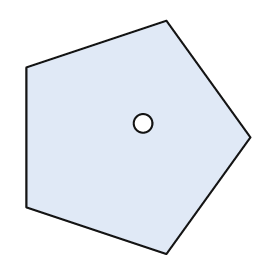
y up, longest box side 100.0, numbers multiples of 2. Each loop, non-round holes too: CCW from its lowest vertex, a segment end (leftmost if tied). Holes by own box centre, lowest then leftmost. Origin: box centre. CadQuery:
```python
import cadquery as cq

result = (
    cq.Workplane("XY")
    .moveTo(12.0, -50.0)
    .lineTo(48.0, 0.0)
    .lineTo(12.0, 50.0)
    .lineTo(-48.0, 30.0)
    .lineTo(-48.0, -30.0)
    .close()
    .moveTo(2.0, 6.0)
    .circle(4.0)
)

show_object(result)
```